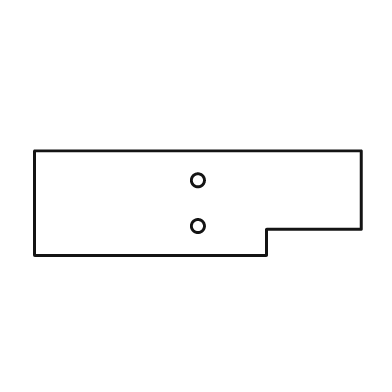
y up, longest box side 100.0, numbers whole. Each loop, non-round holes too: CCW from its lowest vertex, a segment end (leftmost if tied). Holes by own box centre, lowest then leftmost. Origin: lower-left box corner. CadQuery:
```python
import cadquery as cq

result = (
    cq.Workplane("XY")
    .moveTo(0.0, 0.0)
    .lineTo(71.0, 0.0)
    .lineTo(71.0, 8.0)
    .lineTo(100.0, 8.0)
    .lineTo(100.0, 32.0)
    .lineTo(0.0, 32.0)
    .close()
    .moveTo(50.0, 9.0)
    .circle(2.0)
    .moveTo(50.0, 23.0)
    .circle(2.0)
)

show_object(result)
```